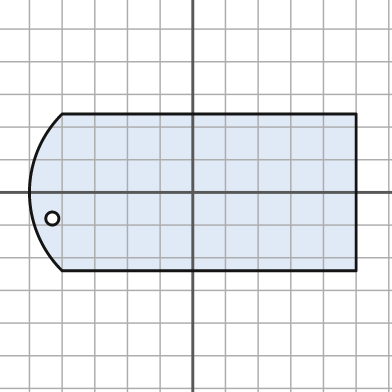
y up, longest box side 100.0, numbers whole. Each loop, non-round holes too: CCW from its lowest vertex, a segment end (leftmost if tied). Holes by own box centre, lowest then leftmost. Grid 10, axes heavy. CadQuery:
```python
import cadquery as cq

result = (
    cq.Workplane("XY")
    .moveTo(-40.0, -24.0)
    .lineTo(50.0, -24.0)
    .lineTo(50.0, 24.0)
    .lineTo(-40.0, 24.0)
    .threePointArc((-50.0, 0.0), (-40.0, -24.0))
    .close()
    .moveTo(-43.0, -8.0)
    .circle(2.0)
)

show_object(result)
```